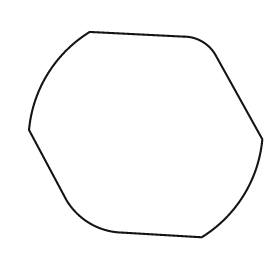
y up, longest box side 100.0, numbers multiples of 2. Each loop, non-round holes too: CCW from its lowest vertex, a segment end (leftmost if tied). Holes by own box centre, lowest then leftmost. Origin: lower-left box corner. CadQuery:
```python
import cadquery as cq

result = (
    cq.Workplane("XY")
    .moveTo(74.0, 0.0)
    .threePointArc((92.0, 18.0), (100.0, 42.0))
    .lineTo(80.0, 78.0)
    .threePointArc((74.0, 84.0), (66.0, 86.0))
    .lineTo(26.0, 88.0)
    .threePointArc((8.0, 70.0), (0.0, 46.0))
    .lineTo(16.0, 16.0)
    .threePointArc((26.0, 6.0), (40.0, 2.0))
    .close()
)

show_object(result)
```